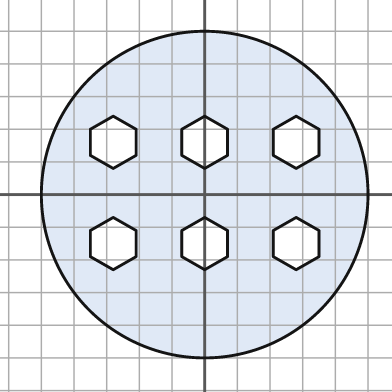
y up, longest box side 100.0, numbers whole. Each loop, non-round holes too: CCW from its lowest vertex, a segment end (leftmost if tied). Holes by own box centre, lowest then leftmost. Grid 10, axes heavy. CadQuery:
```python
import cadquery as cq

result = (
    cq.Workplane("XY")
    .moveTo(0.0, 0.0)
    .circle(50.0)
    .moveTo(-28.0, -23.0)
    .lineTo(-21.0, -19.0)
    .lineTo(-21.0, -11.0)
    .lineTo(-28.0, -7.0)
    .lineTo(-35.0, -11.0)
    .lineTo(-35.0, -19.0)
    .close()
    .moveTo(0.0, -23.0)
    .lineTo(7.0, -19.0)
    .lineTo(7.0, -11.0)
    .lineTo(0.0, -7.0)
    .lineTo(-7.0, -11.0)
    .lineTo(-7.0, -19.0)
    .close()
    .moveTo(28.0, -23.0)
    .lineTo(35.0, -19.0)
    .lineTo(35.0, -11.0)
    .lineTo(28.0, -7.0)
    .lineTo(21.0, -11.0)
    .lineTo(21.0, -19.0)
    .close()
    .moveTo(-28.0, 8.0)
    .lineTo(-21.0, 12.0)
    .lineTo(-21.0, 20.0)
    .lineTo(-28.0, 24.0)
    .lineTo(-35.0, 20.0)
    .lineTo(-35.0, 12.0)
    .close()
    .moveTo(0.0, 8.0)
    .lineTo(7.0, 12.0)
    .lineTo(7.0, 20.0)
    .lineTo(0.0, 24.0)
    .lineTo(-7.0, 20.0)
    .lineTo(-7.0, 12.0)
    .close()
    .moveTo(28.0, 8.0)
    .lineTo(35.0, 12.0)
    .lineTo(35.0, 20.0)
    .lineTo(28.0, 24.0)
    .lineTo(21.0, 20.0)
    .lineTo(21.0, 12.0)
    .close()
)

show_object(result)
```